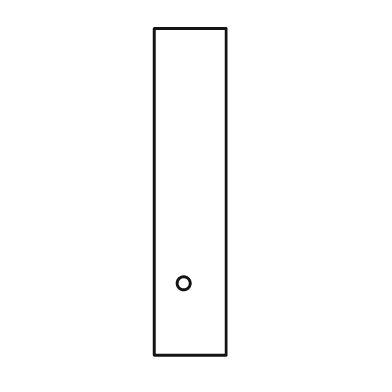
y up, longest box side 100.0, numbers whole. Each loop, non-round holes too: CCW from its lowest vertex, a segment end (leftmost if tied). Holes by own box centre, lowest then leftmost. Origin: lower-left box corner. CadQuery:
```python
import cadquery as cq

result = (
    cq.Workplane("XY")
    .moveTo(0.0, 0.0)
    .lineTo(22.0, 0.0)
    .lineTo(22.0, 100.0)
    .lineTo(0.0, 100.0)
    .close()
    .moveTo(9.0, 22.0)
    .circle(2.0)
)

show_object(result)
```